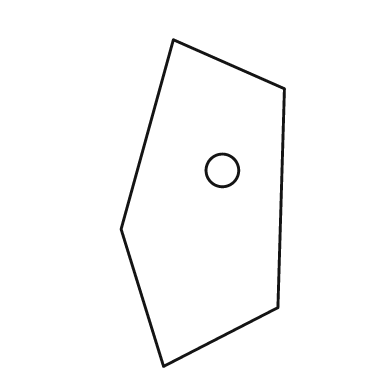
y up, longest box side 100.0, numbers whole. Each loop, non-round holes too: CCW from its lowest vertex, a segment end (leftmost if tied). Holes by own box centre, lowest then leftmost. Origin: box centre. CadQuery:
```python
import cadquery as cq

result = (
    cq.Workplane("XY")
    .moveTo(-12.0, -50.0)
    .lineTo(23.0, -32.0)
    .lineTo(25.0, 35.0)
    .lineTo(-9.0, 50.0)
    .lineTo(-25.0, -8.0)
    .close()
    .moveTo(6.0, 10.0)
    .circle(5.0)
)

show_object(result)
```